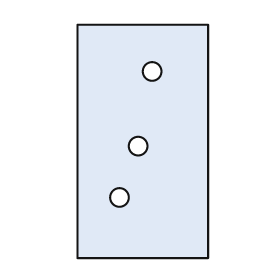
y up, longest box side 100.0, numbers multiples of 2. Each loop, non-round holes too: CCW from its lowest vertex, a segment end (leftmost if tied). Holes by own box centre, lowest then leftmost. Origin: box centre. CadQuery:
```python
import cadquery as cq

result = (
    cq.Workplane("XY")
    .moveTo(-28.0, -50.0)
    .lineTo(28.0, -50.0)
    .lineTo(28.0, 50.0)
    .lineTo(-28.0, 50.0)
    .close()
    .moveTo(-10.0, -24.0)
    .circle(4.0)
    .moveTo(-2.0, -2.0)
    .circle(4.0)
    .moveTo(4.0, 30.0)
    .circle(4.0)
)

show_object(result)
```